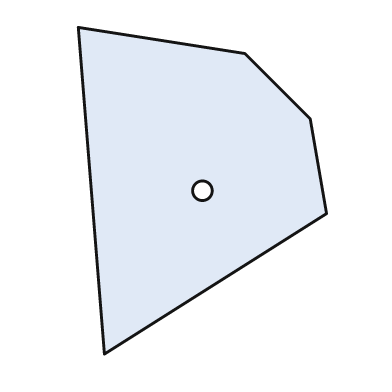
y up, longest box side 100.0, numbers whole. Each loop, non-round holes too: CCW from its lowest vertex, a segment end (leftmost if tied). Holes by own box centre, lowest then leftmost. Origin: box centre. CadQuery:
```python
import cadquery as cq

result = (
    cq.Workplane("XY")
    .moveTo(-30.0, -50.0)
    .lineTo(38.0, -7.0)
    .lineTo(33.0, 22.0)
    .lineTo(13.0, 42.0)
    .lineTo(-38.0, 50.0)
    .close()
    .moveTo(0.0, 0.0)
    .circle(3.0)
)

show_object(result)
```